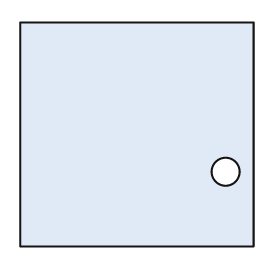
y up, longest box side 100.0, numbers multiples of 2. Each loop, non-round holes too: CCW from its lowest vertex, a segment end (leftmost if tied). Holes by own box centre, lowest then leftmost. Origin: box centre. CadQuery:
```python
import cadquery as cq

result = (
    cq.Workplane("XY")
    .moveTo(-50.0, -48.0)
    .lineTo(50.0, -48.0)
    .lineTo(50.0, 48.0)
    .lineTo(-50.0, 48.0)
    .close()
    .moveTo(38.0, -16.0)
    .circle(6.0)
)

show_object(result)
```